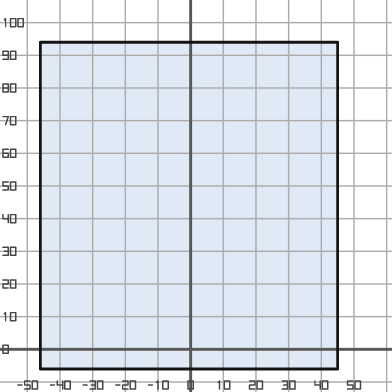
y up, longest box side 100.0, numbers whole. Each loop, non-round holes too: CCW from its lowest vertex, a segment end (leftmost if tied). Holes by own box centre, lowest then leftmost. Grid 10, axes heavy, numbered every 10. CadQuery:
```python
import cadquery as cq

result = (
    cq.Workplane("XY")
    .moveTo(-46.0, -6.0)
    .lineTo(45.0, -6.0)
    .lineTo(45.0, 94.0)
    .lineTo(-46.0, 94.0)
    .close()
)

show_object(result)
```